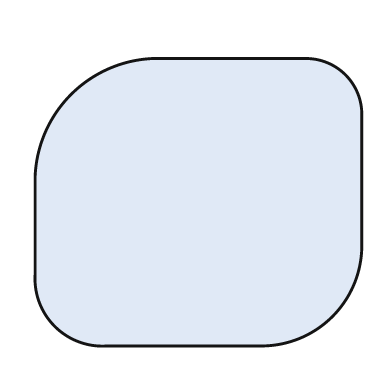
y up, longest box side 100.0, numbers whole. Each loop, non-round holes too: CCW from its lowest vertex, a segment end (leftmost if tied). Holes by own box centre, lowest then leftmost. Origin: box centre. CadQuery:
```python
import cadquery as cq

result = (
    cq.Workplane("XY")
    .moveTo(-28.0, -44.0)
    .lineTo(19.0, -44.0)
    .threePointArc((41.0, -35.0), (50.0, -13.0))
    .lineTo(50.0, 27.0)
    .threePointArc((45.0, 39.0), (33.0, 44.0))
    .lineTo(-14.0, 44.0)
    .threePointArc((-39.0, 33.0), (-50.0, 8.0))
    .lineTo(-50.0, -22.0)
    .threePointArc((-44.0, -38.0), (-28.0, -44.0))
    .close()
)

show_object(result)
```